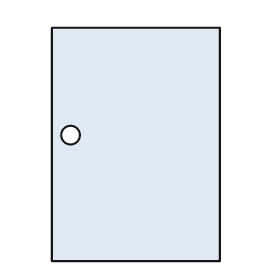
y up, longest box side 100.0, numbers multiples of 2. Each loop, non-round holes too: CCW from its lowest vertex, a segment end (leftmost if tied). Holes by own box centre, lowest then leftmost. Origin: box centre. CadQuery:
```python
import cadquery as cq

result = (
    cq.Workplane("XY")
    .moveTo(-36.0, -50.0)
    .lineTo(36.0, -50.0)
    .lineTo(36.0, 50.0)
    .lineTo(-36.0, 50.0)
    .close()
    .moveTo(-28.0, 4.0)
    .circle(4.0)
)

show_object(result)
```